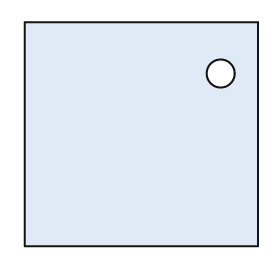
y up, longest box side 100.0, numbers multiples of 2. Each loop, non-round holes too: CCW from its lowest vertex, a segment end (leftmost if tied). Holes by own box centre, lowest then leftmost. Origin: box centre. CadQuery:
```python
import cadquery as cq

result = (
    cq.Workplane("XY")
    .moveTo(-50.0, -48.0)
    .lineTo(50.0, -48.0)
    .lineTo(50.0, 48.0)
    .lineTo(-50.0, 48.0)
    .close()
    .moveTo(34.0, 26.0)
    .circle(6.0)
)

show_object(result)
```